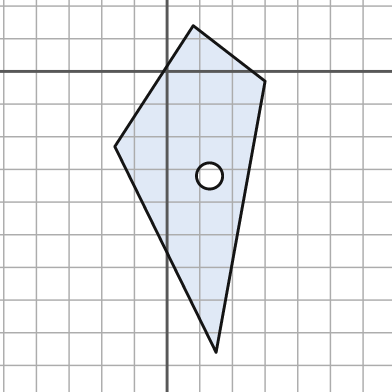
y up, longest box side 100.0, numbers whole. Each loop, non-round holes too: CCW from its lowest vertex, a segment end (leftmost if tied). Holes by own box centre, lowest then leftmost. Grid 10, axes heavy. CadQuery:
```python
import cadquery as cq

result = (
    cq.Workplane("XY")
    .moveTo(15.0, -86.0)
    .lineTo(30.0, -3.0)
    .lineTo(8.0, 14.0)
    .lineTo(-16.0, -23.0)
    .close()
    .moveTo(13.0, -32.0)
    .circle(4.0)
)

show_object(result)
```